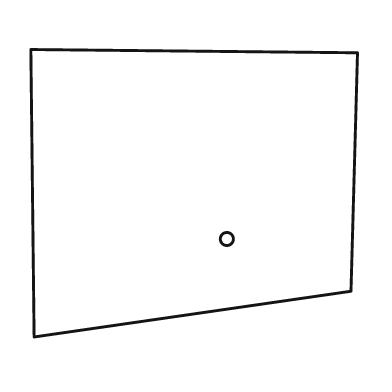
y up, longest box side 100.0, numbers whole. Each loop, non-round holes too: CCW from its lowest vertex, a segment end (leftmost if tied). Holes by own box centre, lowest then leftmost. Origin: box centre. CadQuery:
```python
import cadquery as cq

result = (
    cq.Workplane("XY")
    .moveTo(-49.0, -44.0)
    .lineTo(48.0, -30.0)
    .lineTo(50.0, 43.0)
    .lineTo(-50.0, 44.0)
    .close()
    .moveTo(10.0, -14.0)
    .circle(2.0)
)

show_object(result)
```